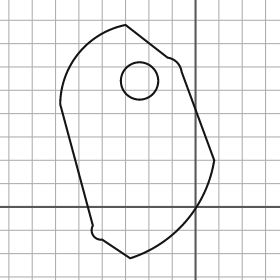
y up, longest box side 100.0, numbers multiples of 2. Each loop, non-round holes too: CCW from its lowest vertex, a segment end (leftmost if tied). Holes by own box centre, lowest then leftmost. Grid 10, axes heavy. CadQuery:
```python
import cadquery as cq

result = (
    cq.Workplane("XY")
    .moveTo(-28.0, -22.0)
    .threePointArc((-4.0, -6.0), (8.0, 20.0))
    .lineTo(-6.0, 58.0)
    .threePointArc((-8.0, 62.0), (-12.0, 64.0))
    .lineTo(-30.0, 78.0)
    .threePointArc((-50.0, 66.0), (-58.0, 44.0))
    .lineTo(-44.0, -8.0)
    .threePointArc((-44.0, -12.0), (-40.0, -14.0))
    .close()
    .moveTo(-24.0, 54.0)
    .circle(8.0)
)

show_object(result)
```